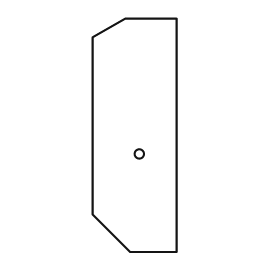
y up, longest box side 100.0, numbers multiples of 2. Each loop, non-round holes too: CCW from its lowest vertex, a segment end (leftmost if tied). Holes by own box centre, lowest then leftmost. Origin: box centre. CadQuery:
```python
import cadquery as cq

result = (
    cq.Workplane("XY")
    .moveTo(-2.0, -50.0)
    .lineTo(18.0, -50.0)
    .lineTo(18.0, 50.0)
    .lineTo(-4.0, 50.0)
    .lineTo(-18.0, 42.0)
    .lineTo(-18.0, -34.0)
    .close()
    .moveTo(2.0, -8.0)
    .circle(2.0)
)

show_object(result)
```